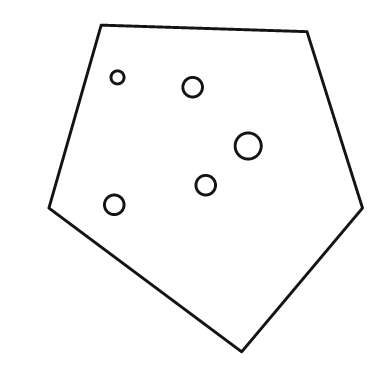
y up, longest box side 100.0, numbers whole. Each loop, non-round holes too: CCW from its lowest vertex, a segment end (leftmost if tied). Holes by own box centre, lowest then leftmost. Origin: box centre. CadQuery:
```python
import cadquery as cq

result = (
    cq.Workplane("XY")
    .moveTo(11.0, -50.0)
    .lineTo(48.0, -6.0)
    .lineTo(31.0, 48.0)
    .lineTo(-32.0, 50.0)
    .lineTo(-48.0, -6.0)
    .close()
    .moveTo(-28.0, -5.0)
    .circle(3.0)
    .moveTo(0.0, 1.0)
    .circle(3.0)
    .moveTo(13.0, 13.0)
    .circle(4.0)
    .moveTo(-4.0, 31.0)
    .circle(3.0)
    .moveTo(-27.0, 34.0)
    .circle(2.0)
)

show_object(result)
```